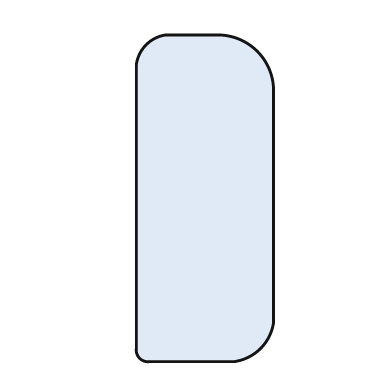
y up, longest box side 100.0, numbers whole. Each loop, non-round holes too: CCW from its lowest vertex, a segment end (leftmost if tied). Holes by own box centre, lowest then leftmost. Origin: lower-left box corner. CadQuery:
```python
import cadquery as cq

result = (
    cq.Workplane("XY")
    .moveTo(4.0, 0.0)
    .lineTo(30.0, 0.0)
    .threePointArc((38.0, 4.0), (42.0, 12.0))
    .lineTo(42.0, 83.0)
    .threePointArc((37.0, 95.0), (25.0, 100.0))
    .lineTo(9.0, 100.0)
    .threePointArc((3.0, 97.0), (0.0, 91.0))
    .lineTo(0.0, 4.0)
    .threePointArc((1.0, 1.0), (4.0, 0.0))
    .close()
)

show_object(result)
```